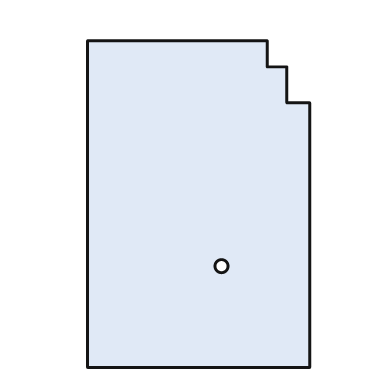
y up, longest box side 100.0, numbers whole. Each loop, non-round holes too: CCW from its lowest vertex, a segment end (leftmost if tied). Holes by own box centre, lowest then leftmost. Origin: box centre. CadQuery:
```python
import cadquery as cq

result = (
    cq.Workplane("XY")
    .moveTo(-34.0, -50.0)
    .lineTo(34.0, -50.0)
    .lineTo(34.0, 31.0)
    .lineTo(27.0, 31.0)
    .lineTo(27.0, 42.0)
    .lineTo(21.0, 42.0)
    .lineTo(21.0, 50.0)
    .lineTo(-34.0, 50.0)
    .close()
    .moveTo(7.0, -19.0)
    .circle(2.0)
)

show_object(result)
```